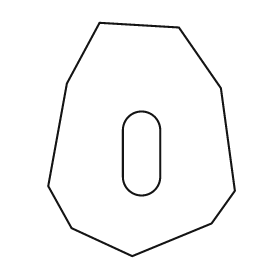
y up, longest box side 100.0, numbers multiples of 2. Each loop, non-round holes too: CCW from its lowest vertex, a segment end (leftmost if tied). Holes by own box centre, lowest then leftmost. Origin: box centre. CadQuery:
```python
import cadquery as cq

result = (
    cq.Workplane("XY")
    .moveTo(-4.0, -50.0)
    .lineTo(30.0, -36.0)
    .lineTo(40.0, -22.0)
    .lineTo(34.0, 22.0)
    .lineTo(16.0, 48.0)
    .lineTo(-18.0, 50.0)
    .lineTo(-32.0, 24.0)
    .lineTo(-40.0, -20.0)
    .lineTo(-30.0, -38.0)
    .close()
    .moveTo(-8.0, -16.0)
    .threePointArc((0.0, -24.0), (8.0, -16.0))
    .lineTo(8.0, 4.0)
    .threePointArc((0.0, 12.0), (-8.0, 4.0))
    .close()
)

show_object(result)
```